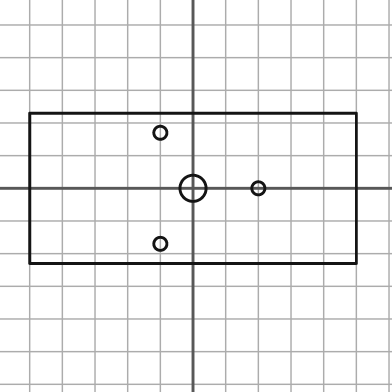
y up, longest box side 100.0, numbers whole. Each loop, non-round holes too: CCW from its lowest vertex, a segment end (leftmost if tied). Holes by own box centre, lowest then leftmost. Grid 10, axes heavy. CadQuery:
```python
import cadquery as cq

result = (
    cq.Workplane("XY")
    .moveTo(-50.0, -23.0)
    .lineTo(50.0, -23.0)
    .lineTo(50.0, 23.0)
    .lineTo(-50.0, 23.0)
    .close()
    .moveTo(-10.0, -17.0)
    .circle(2.0)
    .moveTo(0.0, 0.0)
    .circle(4.0)
    .moveTo(20.0, 0.0)
    .circle(2.0)
    .moveTo(-10.0, 17.0)
    .circle(2.0)
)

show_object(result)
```